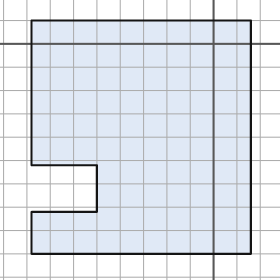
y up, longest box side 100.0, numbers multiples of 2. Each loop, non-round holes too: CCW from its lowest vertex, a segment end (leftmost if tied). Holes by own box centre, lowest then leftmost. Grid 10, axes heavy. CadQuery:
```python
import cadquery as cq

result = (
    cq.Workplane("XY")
    .moveTo(-78.0, -90.0)
    .lineTo(16.0, -90.0)
    .lineTo(16.0, 10.0)
    .lineTo(-78.0, 10.0)
    .lineTo(-78.0, -52.0)
    .lineTo(-50.0, -52.0)
    .lineTo(-50.0, -72.0)
    .lineTo(-78.0, -72.0)
    .close()
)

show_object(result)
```